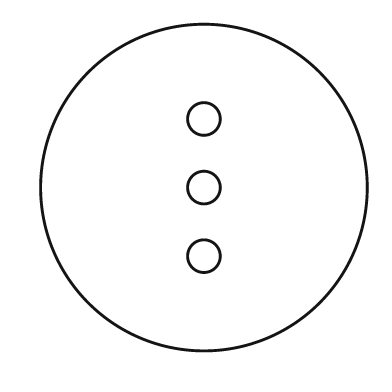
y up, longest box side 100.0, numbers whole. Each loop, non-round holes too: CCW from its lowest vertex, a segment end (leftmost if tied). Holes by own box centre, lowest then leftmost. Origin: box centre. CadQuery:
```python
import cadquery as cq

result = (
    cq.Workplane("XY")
    .moveTo(0.0, 0.0)
    .circle(50.0)
    .moveTo(0.0, -21.0)
    .circle(5.0)
    .moveTo(0.0, 0.0)
    .circle(5.0)
    .moveTo(0.0, 21.0)
    .circle(5.0)
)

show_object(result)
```